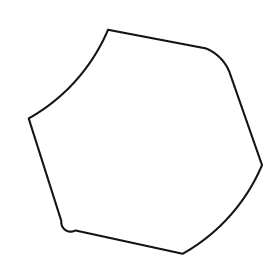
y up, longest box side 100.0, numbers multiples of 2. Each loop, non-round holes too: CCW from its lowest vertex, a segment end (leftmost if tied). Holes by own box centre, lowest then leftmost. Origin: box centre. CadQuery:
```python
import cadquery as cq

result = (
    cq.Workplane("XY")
    .moveTo(16.0, -48.0)
    .threePointArc((36.0, -32.0), (50.0, -10.0))
    .lineTo(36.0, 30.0)
    .threePointArc((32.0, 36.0), (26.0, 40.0))
    .lineTo(-16.0, 48.0)
    .threePointArc((-30.0, 26.0), (-50.0, 10.0))
    .lineTo(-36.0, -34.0)
    .threePointArc((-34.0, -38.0), (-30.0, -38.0))
    .close()
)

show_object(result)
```